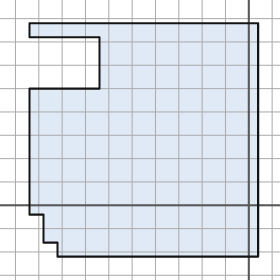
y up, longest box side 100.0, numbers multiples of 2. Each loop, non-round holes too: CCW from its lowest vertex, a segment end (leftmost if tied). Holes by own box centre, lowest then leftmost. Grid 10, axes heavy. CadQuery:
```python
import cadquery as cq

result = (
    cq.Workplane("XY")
    .moveTo(-82.0, -22.0)
    .lineTo(4.0, -22.0)
    .lineTo(4.0, 78.0)
    .lineTo(-94.0, 78.0)
    .lineTo(-94.0, 72.0)
    .lineTo(-64.0, 72.0)
    .lineTo(-64.0, 50.0)
    .lineTo(-94.0, 50.0)
    .lineTo(-94.0, -4.0)
    .lineTo(-88.0, -4.0)
    .lineTo(-88.0, -16.0)
    .lineTo(-82.0, -16.0)
    .close()
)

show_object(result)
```